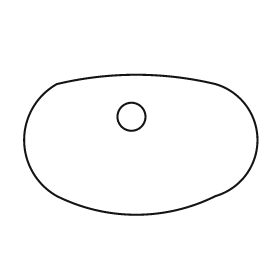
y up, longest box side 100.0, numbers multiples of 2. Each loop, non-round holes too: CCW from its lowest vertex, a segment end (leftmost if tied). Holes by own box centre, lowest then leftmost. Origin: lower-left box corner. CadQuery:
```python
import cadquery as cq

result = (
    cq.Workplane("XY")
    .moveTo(14.0, 8.0)
    .threePointArc((48.0, 0.0), (82.0, 8.0))
    .threePointArc((100.0, 32.0), (82.0, 56.0))
    .threePointArc((48.0, 60.0), (14.0, 56.0))
    .threePointArc((0.0, 32.0), (14.0, 8.0))
    .close()
    .moveTo(46.0, 42.0)
    .circle(6.0)
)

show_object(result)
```